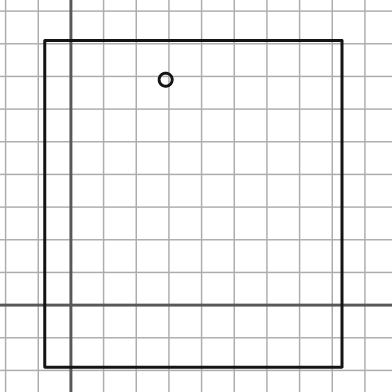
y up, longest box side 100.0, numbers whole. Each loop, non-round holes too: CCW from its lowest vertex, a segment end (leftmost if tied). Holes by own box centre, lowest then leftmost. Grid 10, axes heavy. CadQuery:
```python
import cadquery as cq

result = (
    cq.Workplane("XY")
    .moveTo(-8.0, -19.0)
    .lineTo(83.0, -19.0)
    .lineTo(83.0, 81.0)
    .lineTo(-8.0, 81.0)
    .close()
    .moveTo(29.0, 69.0)
    .circle(2.0)
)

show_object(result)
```